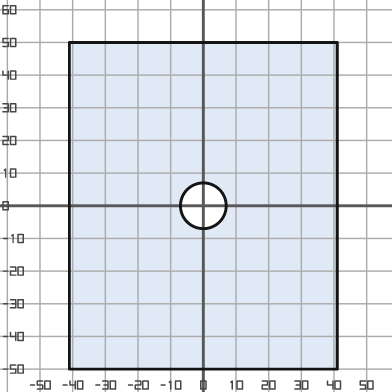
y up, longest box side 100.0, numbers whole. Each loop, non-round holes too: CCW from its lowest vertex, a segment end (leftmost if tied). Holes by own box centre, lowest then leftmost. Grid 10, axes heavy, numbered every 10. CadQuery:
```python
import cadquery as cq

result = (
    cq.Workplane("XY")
    .moveTo(-41.0, -50.0)
    .lineTo(41.0, -50.0)
    .lineTo(41.0, 50.0)
    .lineTo(-41.0, 50.0)
    .close()
    .moveTo(0.0, 0.0)
    .circle(7.0)
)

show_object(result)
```